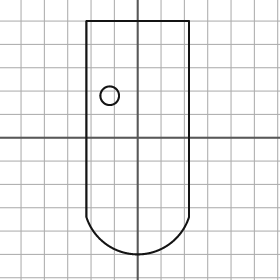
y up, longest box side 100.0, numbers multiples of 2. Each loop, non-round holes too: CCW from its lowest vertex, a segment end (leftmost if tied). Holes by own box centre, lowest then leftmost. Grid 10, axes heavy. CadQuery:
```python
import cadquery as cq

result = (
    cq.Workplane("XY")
    .moveTo(-22.0, -34.0)
    .threePointArc((0.0, -50.0), (22.0, -34.0))
    .lineTo(22.0, 50.0)
    .lineTo(-22.0, 50.0)
    .close()
    .moveTo(-12.0, 18.0)
    .circle(4.0)
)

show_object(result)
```